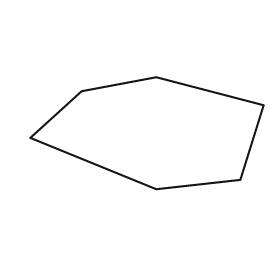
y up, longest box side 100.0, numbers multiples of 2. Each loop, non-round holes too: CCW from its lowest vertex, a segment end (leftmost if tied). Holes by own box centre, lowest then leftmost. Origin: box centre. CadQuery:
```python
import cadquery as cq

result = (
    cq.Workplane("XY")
    .moveTo(4.0, -24.0)
    .lineTo(40.0, -20.0)
    .lineTo(50.0, 12.0)
    .lineTo(4.0, 24.0)
    .lineTo(-28.0, 18.0)
    .lineTo(-50.0, -2.0)
    .close()
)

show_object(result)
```